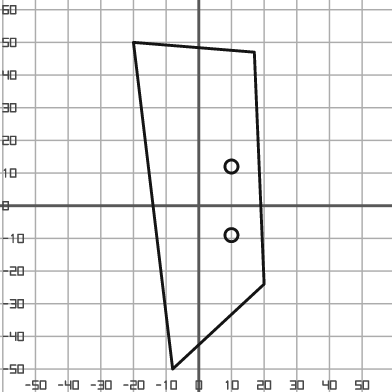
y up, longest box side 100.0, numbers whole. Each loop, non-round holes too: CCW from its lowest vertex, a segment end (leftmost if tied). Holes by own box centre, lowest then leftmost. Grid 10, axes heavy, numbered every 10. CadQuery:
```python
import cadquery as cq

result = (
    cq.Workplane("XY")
    .moveTo(-8.0, -50.0)
    .lineTo(20.0, -24.0)
    .lineTo(17.0, 47.0)
    .lineTo(-20.0, 50.0)
    .close()
    .moveTo(10.0, -9.0)
    .circle(2.0)
    .moveTo(10.0, 12.0)
    .circle(2.0)
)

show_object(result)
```